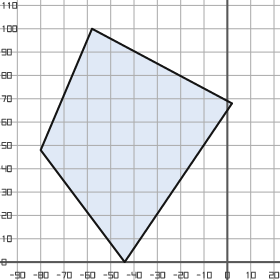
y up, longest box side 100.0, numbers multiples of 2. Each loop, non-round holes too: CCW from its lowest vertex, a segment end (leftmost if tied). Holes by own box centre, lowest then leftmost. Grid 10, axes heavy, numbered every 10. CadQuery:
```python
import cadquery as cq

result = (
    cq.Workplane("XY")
    .moveTo(-44.0, 0.0)
    .lineTo(2.0, 68.0)
    .lineTo(-58.0, 100.0)
    .lineTo(-80.0, 48.0)
    .close()
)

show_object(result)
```